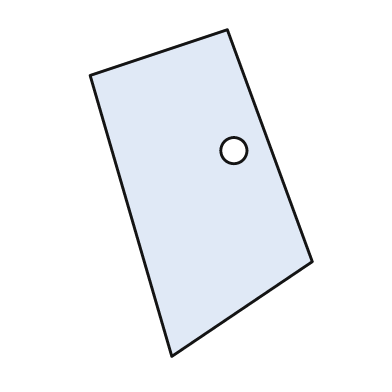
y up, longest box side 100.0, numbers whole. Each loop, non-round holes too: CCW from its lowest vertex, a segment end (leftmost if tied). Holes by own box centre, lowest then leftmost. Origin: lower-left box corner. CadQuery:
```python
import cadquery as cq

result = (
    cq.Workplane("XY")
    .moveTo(25.0, 0.0)
    .lineTo(68.0, 29.0)
    .lineTo(42.0, 100.0)
    .lineTo(0.0, 86.0)
    .close()
    .moveTo(44.0, 63.0)
    .circle(4.0)
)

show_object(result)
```